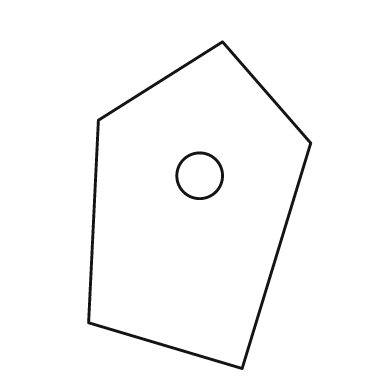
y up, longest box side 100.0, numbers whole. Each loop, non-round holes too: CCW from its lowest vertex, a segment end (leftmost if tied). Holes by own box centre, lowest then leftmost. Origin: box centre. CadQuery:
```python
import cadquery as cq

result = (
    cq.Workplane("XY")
    .moveTo(13.0, -50.0)
    .lineTo(34.0, 19.0)
    .lineTo(7.0, 50.0)
    .lineTo(-31.0, 26.0)
    .lineTo(-34.0, -36.0)
    .close()
    .moveTo(0.0, 9.0)
    .circle(7.0)
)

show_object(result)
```